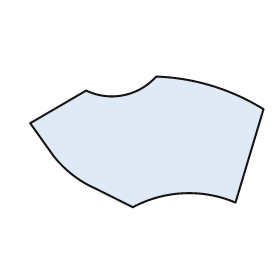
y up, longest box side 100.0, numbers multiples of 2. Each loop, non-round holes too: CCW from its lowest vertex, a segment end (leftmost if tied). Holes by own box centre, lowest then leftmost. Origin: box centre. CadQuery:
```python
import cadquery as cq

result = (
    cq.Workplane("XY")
    .moveTo(-6.0, -28.0)
    .threePointArc((16.0, -22.0), (38.0, -26.0))
    .lineTo(50.0, 14.0)
    .threePointArc((28.0, 24.0), (4.0, 28.0))
    .threePointArc((-10.0, 20.0), (-26.0, 22.0))
    .lineTo(-50.0, 8.0)
    .lineTo(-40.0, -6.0)
    .threePointArc((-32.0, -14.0), (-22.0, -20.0))
    .close()
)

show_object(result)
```